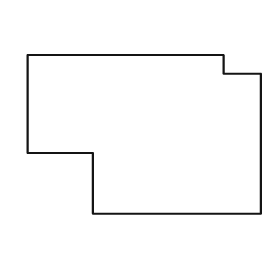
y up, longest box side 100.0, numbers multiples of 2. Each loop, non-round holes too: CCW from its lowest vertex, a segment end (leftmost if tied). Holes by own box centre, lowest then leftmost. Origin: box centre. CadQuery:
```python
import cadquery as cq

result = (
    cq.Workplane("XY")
    .moveTo(-22.0, -34.0)
    .lineTo(50.0, -34.0)
    .lineTo(50.0, 26.0)
    .lineTo(34.0, 26.0)
    .lineTo(34.0, 34.0)
    .lineTo(-50.0, 34.0)
    .lineTo(-50.0, -8.0)
    .lineTo(-22.0, -8.0)
    .close()
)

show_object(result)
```